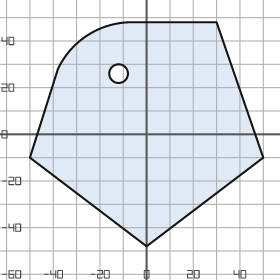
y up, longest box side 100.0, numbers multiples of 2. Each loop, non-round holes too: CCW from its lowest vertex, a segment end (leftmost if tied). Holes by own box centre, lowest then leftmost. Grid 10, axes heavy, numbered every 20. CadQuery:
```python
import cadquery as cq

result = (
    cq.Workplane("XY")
    .moveTo(0.0, -48.0)
    .lineTo(50.0, -10.0)
    .lineTo(30.0, 48.0)
    .lineTo(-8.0, 48.0)
    .threePointArc((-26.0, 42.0), (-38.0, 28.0))
    .lineTo(-50.0, -10.0)
    .close()
    .moveTo(-12.0, 26.0)
    .circle(4.0)
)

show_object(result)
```